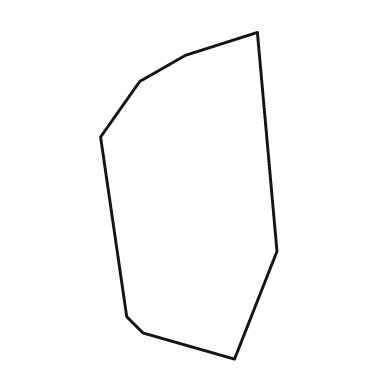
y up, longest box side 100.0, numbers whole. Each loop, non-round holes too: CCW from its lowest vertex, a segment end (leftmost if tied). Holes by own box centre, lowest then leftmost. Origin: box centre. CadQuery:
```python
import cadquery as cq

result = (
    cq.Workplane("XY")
    .moveTo(14.0, -50.0)
    .lineTo(27.0, -17.0)
    .lineTo(21.0, 50.0)
    .lineTo(-1.0, 43.0)
    .lineTo(-15.0, 35.0)
    .lineTo(-27.0, 18.0)
    .lineTo(-19.0, -37.0)
    .lineTo(-14.0, -42.0)
    .close()
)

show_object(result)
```